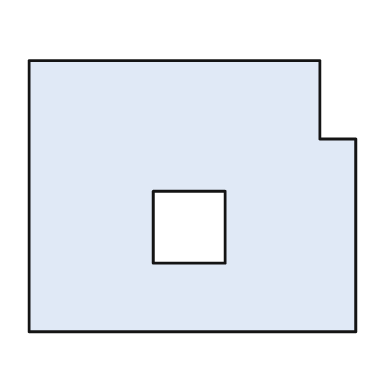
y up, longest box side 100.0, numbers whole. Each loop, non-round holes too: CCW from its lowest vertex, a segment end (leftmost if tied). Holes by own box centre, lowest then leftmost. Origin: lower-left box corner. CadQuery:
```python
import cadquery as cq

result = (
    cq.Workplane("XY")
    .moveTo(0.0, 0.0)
    .lineTo(100.0, 0.0)
    .lineTo(100.0, 59.0)
    .lineTo(89.0, 59.0)
    .lineTo(89.0, 83.0)
    .lineTo(0.0, 83.0)
    .close()
    .moveTo(38.0, 21.0)
    .lineTo(60.0, 21.0)
    .lineTo(60.0, 43.0)
    .lineTo(38.0, 43.0)
    .close()
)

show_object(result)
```